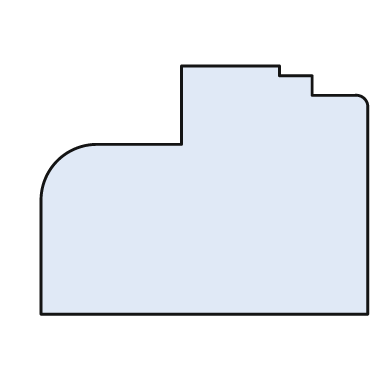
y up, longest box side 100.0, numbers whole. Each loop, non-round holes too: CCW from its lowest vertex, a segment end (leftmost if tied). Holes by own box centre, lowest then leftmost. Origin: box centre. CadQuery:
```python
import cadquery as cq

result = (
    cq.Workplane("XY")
    .moveTo(-50.0, -38.0)
    .lineTo(50.0, -38.0)
    .lineTo(50.0, 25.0)
    .threePointArc((49.0, 28.0), (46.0, 29.0))
    .lineTo(33.0, 29.0)
    .lineTo(33.0, 35.0)
    .lineTo(23.0, 35.0)
    .lineTo(23.0, 38.0)
    .lineTo(-7.0, 38.0)
    .lineTo(-7.0, 14.0)
    .lineTo(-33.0, 14.0)
    .threePointArc((-45.0, 9.0), (-50.0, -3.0))
    .close()
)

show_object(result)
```